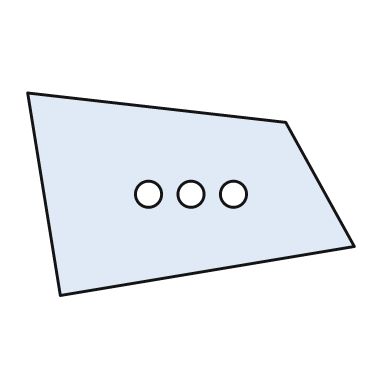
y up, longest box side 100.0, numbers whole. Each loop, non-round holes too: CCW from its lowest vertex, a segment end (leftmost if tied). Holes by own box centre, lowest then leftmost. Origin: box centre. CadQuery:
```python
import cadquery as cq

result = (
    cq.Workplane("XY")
    .moveTo(-40.0, -31.0)
    .lineTo(50.0, -16.0)
    .lineTo(29.0, 22.0)
    .lineTo(-50.0, 31.0)
    .close()
    .moveTo(-13.0, 0.0)
    .circle(4.0)
    .moveTo(0.0, 0.0)
    .circle(4.0)
    .moveTo(13.0, 0.0)
    .circle(4.0)
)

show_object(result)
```